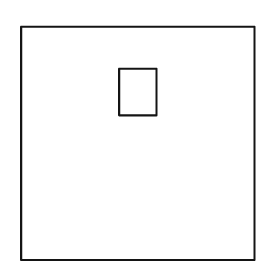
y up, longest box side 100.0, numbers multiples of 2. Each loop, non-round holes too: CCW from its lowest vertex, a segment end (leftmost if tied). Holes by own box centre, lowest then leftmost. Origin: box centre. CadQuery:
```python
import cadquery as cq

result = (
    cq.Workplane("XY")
    .moveTo(-50.0, -50.0)
    .lineTo(50.0, -50.0)
    .lineTo(50.0, 50.0)
    .lineTo(-50.0, 50.0)
    .close()
    .moveTo(-8.0, 12.0)
    .lineTo(8.0, 12.0)
    .lineTo(8.0, 32.0)
    .lineTo(-8.0, 32.0)
    .close()
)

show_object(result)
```